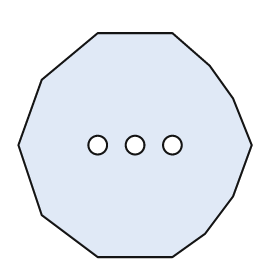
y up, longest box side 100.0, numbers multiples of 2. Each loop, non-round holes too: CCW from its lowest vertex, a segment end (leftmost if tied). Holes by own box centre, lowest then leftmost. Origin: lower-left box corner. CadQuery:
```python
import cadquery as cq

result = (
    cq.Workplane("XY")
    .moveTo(34.0, 0.0)
    .lineTo(66.0, 0.0)
    .lineTo(80.0, 10.0)
    .lineTo(92.0, 26.0)
    .lineTo(100.0, 48.0)
    .lineTo(92.0, 68.0)
    .lineTo(82.0, 82.0)
    .lineTo(66.0, 96.0)
    .lineTo(34.0, 96.0)
    .lineTo(10.0, 76.0)
    .lineTo(0.0, 48.0)
    .lineTo(10.0, 18.0)
    .close()
    .moveTo(34.0, 48.0)
    .circle(4.0)
    .moveTo(50.0, 48.0)
    .circle(4.0)
    .moveTo(66.0, 48.0)
    .circle(4.0)
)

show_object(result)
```